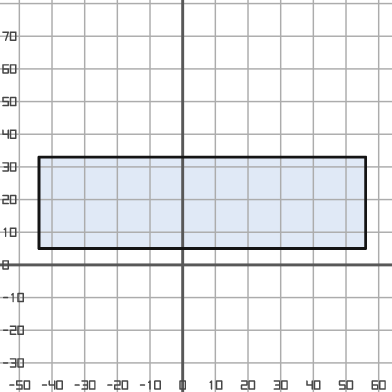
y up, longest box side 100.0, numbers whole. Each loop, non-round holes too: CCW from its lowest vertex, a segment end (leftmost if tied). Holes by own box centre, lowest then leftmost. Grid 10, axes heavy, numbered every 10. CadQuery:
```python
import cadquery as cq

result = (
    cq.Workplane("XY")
    .moveTo(-44.0, 5.0)
    .lineTo(56.0, 5.0)
    .lineTo(56.0, 33.0)
    .lineTo(-44.0, 33.0)
    .close()
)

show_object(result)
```